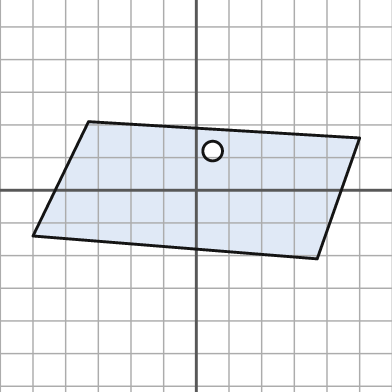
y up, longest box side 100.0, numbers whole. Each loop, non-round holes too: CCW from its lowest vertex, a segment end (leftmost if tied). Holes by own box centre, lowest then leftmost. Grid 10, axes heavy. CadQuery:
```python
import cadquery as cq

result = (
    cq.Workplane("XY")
    .moveTo(37.0, -21.0)
    .lineTo(50.0, 16.0)
    .lineTo(-33.0, 21.0)
    .lineTo(-50.0, -14.0)
    .close()
    .moveTo(5.0, 12.0)
    .circle(3.0)
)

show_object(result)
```